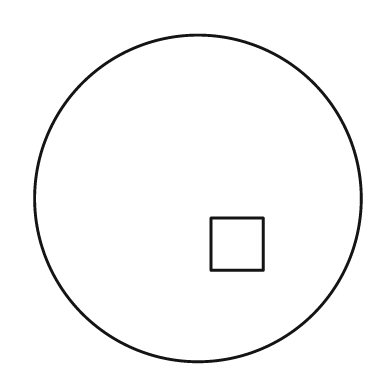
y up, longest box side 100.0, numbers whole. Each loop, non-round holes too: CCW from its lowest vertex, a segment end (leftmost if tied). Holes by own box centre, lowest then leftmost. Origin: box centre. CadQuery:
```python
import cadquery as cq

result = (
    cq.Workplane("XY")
    .moveTo(0.0, 0.0)
    .circle(50.0)
    .moveTo(4.0, -22.0)
    .lineTo(20.0, -22.0)
    .lineTo(20.0, -6.0)
    .lineTo(4.0, -6.0)
    .close()
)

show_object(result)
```